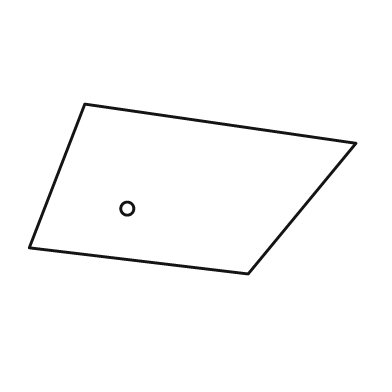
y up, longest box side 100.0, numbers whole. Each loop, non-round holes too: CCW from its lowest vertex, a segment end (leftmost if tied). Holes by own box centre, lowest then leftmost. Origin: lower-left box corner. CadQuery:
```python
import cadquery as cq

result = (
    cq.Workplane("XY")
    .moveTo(67.0, 0.0)
    .lineTo(100.0, 40.0)
    .lineTo(17.0, 52.0)
    .lineTo(0.0, 8.0)
    .close()
    .moveTo(30.0, 20.0)
    .circle(2.0)
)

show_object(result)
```